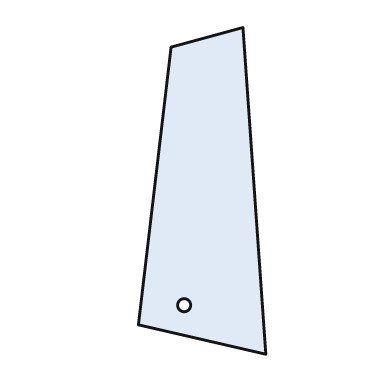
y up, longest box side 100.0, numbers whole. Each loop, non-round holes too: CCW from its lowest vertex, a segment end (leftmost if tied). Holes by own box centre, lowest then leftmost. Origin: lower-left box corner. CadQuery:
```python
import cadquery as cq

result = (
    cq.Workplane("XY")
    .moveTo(39.0, 0.0)
    .lineTo(32.0, 100.0)
    .lineTo(10.0, 94.0)
    .lineTo(0.0, 9.0)
    .close()
    .moveTo(14.0, 15.0)
    .circle(2.0)
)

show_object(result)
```